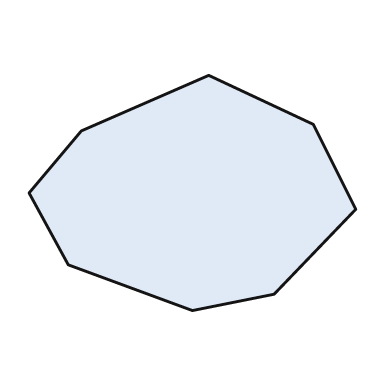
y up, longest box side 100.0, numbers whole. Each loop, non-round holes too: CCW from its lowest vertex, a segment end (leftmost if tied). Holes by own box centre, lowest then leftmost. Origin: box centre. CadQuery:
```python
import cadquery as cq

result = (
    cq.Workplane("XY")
    .moveTo(0.0, -36.0)
    .lineTo(25.0, -31.0)
    .lineTo(50.0, -5.0)
    .lineTo(37.0, 21.0)
    .lineTo(5.0, 36.0)
    .lineTo(-34.0, 19.0)
    .lineTo(-50.0, 0.0)
    .lineTo(-38.0, -22.0)
    .close()
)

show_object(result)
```